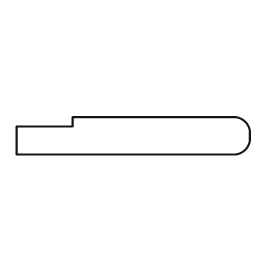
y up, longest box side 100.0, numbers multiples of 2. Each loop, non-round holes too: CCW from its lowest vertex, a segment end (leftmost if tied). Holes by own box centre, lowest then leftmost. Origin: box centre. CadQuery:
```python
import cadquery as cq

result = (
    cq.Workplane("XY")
    .moveTo(-50.0, -8.0)
    .lineTo(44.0, -8.0)
    .threePointArc((48.0, -6.0), (50.0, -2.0))
    .lineTo(50.0, 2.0)
    .threePointArc((48.0, 6.0), (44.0, 8.0))
    .lineTo(-26.0, 8.0)
    .lineTo(-26.0, 4.0)
    .lineTo(-50.0, 4.0)
    .close()
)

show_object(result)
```